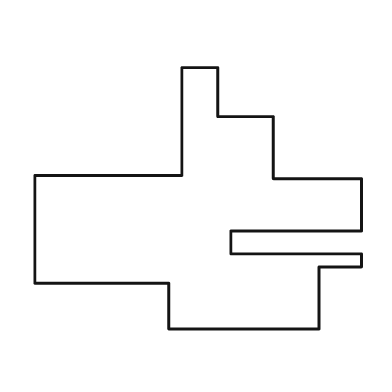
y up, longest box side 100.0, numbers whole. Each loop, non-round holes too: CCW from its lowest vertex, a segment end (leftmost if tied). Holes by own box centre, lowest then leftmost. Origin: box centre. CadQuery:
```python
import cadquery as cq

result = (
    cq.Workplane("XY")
    .moveTo(-9.0, -40.0)
    .lineTo(37.0, -40.0)
    .lineTo(37.0, -21.0)
    .lineTo(50.0, -21.0)
    .lineTo(50.0, -17.0)
    .lineTo(10.0, -17.0)
    .lineTo(10.0, -10.0)
    .lineTo(50.0, -10.0)
    .lineTo(50.0, 6.0)
    .lineTo(23.0, 6.0)
    .lineTo(23.0, 25.0)
    .lineTo(6.0, 25.0)
    .lineTo(6.0, 40.0)
    .lineTo(-5.0, 40.0)
    .lineTo(-5.0, 7.0)
    .lineTo(-50.0, 7.0)
    .lineTo(-50.0, -26.0)
    .lineTo(-9.0, -26.0)
    .close()
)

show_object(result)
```